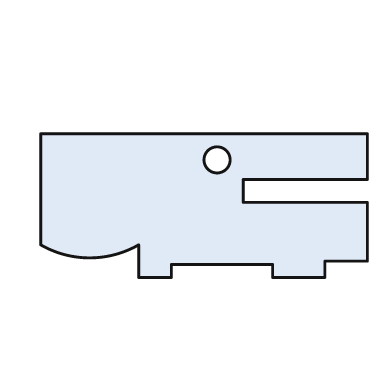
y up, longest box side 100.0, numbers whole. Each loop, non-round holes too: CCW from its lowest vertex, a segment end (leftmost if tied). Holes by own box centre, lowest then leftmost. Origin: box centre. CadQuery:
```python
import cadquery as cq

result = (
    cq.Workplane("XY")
    .moveTo(-20.0, -22.0)
    .lineTo(-10.0, -22.0)
    .lineTo(-10.0, -18.0)
    .lineTo(21.0, -18.0)
    .lineTo(21.0, -22.0)
    .lineTo(37.0, -22.0)
    .lineTo(37.0, -17.0)
    .lineTo(50.0, -17.0)
    .lineTo(50.0, 1.0)
    .lineTo(12.0, 1.0)
    .lineTo(12.0, 8.0)
    .lineTo(50.0, 8.0)
    .lineTo(50.0, 22.0)
    .lineTo(-50.0, 22.0)
    .lineTo(-50.0, -12.0)
    .threePointArc((-35.0, -16.0), (-20.0, -12.0))
    .close()
    .moveTo(4.0, 14.0)
    .circle(4.0)
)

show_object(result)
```